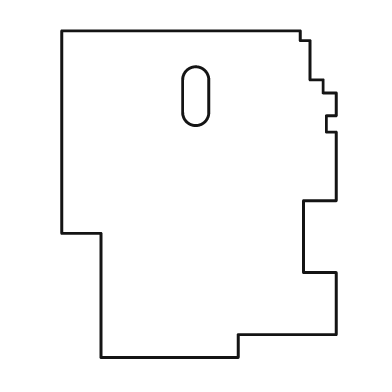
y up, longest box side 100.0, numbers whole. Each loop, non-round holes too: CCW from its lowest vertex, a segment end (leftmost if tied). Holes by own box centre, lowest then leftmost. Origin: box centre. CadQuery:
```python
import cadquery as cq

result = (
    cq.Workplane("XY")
    .moveTo(-30.0, -50.0)
    .lineTo(12.0, -50.0)
    .lineTo(12.0, -43.0)
    .lineTo(42.0, -43.0)
    .lineTo(42.0, -24.0)
    .lineTo(32.0, -24.0)
    .lineTo(32.0, -2.0)
    .lineTo(42.0, -2.0)
    .lineTo(42.0, 19.0)
    .lineTo(39.0, 19.0)
    .lineTo(39.0, 24.0)
    .lineTo(42.0, 24.0)
    .lineTo(42.0, 31.0)
    .lineTo(38.0, 31.0)
    .lineTo(38.0, 35.0)
    .lineTo(34.0, 35.0)
    .lineTo(34.0, 47.0)
    .lineTo(31.0, 47.0)
    .lineTo(31.0, 50.0)
    .lineTo(-42.0, 50.0)
    .lineTo(-42.0, -12.0)
    .lineTo(-30.0, -12.0)
    .close()
    .moveTo(-5.0, 25.0)
    .threePointArc((-1.0, 21.0), (3.0, 25.0))
    .lineTo(3.0, 35.0)
    .threePointArc((-1.0, 39.0), (-5.0, 35.0))
    .close()
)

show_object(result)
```